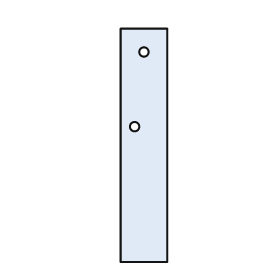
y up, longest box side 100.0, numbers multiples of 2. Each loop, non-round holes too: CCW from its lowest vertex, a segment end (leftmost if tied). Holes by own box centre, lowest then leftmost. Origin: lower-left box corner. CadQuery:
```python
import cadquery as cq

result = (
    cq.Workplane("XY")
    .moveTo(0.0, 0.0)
    .lineTo(20.0, 0.0)
    .lineTo(20.0, 100.0)
    .lineTo(0.0, 100.0)
    .close()
    .moveTo(6.0, 58.0)
    .circle(2.0)
    .moveTo(10.0, 90.0)
    .circle(2.0)
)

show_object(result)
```